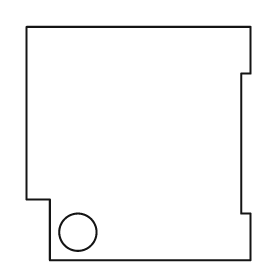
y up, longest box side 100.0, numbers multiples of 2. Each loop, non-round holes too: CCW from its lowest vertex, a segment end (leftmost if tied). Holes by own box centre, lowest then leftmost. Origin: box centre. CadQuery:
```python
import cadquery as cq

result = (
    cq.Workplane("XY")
    .moveTo(-38.0, -50.0)
    .lineTo(48.0, -50.0)
    .lineTo(48.0, -30.0)
    .lineTo(44.0, -30.0)
    .lineTo(44.0, 30.0)
    .lineTo(48.0, 30.0)
    .lineTo(48.0, 50.0)
    .lineTo(-48.0, 50.0)
    .lineTo(-48.0, -24.0)
    .lineTo(-38.0, -24.0)
    .close()
    .moveTo(-26.0, -38.0)
    .circle(8.0)
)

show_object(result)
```